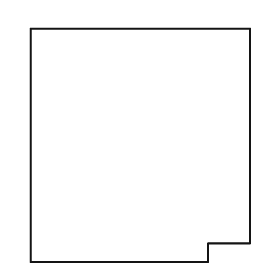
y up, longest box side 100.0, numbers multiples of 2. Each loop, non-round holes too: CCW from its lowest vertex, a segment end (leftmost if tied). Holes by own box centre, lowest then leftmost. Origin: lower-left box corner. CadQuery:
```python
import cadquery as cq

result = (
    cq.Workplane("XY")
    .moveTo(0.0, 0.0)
    .lineTo(76.0, 0.0)
    .lineTo(76.0, 8.0)
    .lineTo(94.0, 8.0)
    .lineTo(94.0, 100.0)
    .lineTo(0.0, 100.0)
    .close()
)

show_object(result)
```